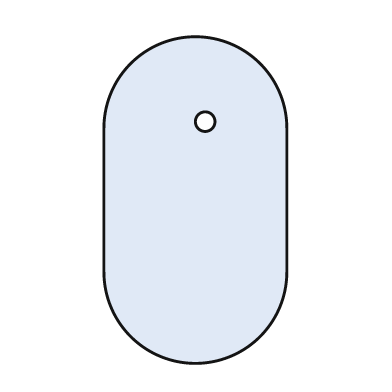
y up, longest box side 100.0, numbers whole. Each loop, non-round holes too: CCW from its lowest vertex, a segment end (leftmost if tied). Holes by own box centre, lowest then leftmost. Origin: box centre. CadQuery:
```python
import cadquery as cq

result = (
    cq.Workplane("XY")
    .moveTo(-28.0, -22.0)
    .threePointArc((0.0, -50.0), (28.0, -22.0))
    .lineTo(28.0, 22.0)
    .threePointArc((0.0, 50.0), (-28.0, 22.0))
    .close()
    .moveTo(3.0, 24.0)
    .circle(3.0)
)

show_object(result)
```